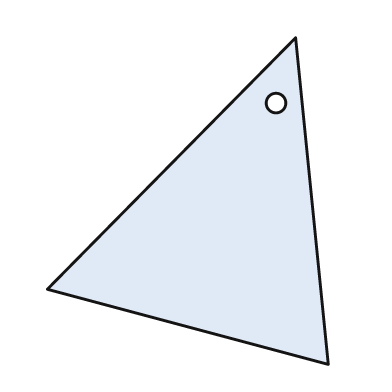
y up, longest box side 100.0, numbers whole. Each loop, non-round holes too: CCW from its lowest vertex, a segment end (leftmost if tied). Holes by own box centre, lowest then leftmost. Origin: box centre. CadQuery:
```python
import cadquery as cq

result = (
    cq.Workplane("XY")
    .moveTo(43.0, -50.0)
    .lineTo(33.0, 50.0)
    .lineTo(-43.0, -27.0)
    .close()
    .moveTo(27.0, 30.0)
    .circle(3.0)
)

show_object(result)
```